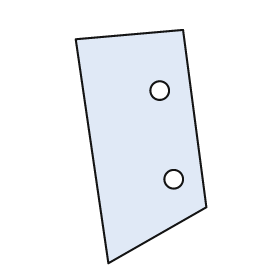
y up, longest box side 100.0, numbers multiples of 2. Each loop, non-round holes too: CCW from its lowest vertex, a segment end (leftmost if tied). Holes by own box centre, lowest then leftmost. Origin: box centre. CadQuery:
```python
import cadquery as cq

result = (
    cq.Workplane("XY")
    .moveTo(-14.0, -50.0)
    .lineTo(28.0, -26.0)
    .lineTo(18.0, 50.0)
    .lineTo(-28.0, 46.0)
    .close()
    .moveTo(14.0, -14.0)
    .circle(4.0)
    .moveTo(8.0, 24.0)
    .circle(4.0)
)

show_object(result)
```